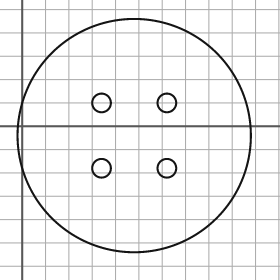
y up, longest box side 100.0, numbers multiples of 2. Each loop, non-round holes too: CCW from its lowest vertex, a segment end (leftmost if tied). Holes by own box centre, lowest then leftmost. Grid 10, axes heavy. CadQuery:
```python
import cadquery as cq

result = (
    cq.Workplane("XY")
    .moveTo(48.0, -4.0)
    .circle(50.0)
    .moveTo(34.0, -18.0)
    .circle(4.0)
    .moveTo(62.0, -18.0)
    .circle(4.0)
    .moveTo(34.0, 10.0)
    .circle(4.0)
    .moveTo(62.0, 10.0)
    .circle(4.0)
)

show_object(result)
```